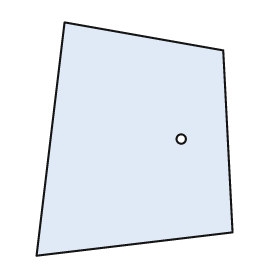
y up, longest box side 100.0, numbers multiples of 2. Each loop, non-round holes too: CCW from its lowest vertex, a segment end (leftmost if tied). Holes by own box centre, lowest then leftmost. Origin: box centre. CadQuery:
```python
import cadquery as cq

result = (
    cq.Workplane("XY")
    .moveTo(-42.0, -50.0)
    .lineTo(42.0, -40.0)
    .lineTo(38.0, 38.0)
    .lineTo(-30.0, 50.0)
    .close()
    .moveTo(20.0, 0.0)
    .circle(2.0)
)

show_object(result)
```